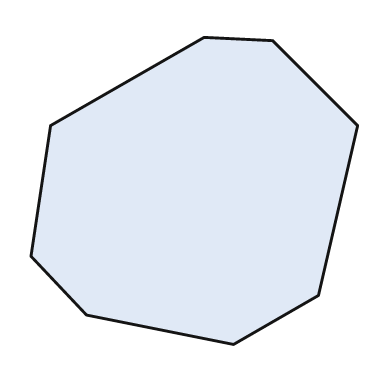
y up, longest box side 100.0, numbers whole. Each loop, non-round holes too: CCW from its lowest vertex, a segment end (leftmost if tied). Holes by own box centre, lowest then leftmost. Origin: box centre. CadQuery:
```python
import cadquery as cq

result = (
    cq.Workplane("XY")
    .moveTo(12.0, -47.0)
    .lineTo(38.0, -32.0)
    .lineTo(50.0, 20.0)
    .lineTo(24.0, 46.0)
    .lineTo(3.0, 47.0)
    .lineTo(-44.0, 20.0)
    .lineTo(-50.0, -20.0)
    .lineTo(-33.0, -38.0)
    .close()
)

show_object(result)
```